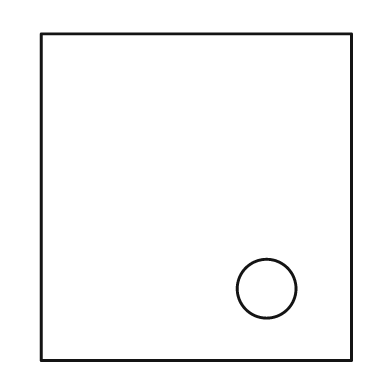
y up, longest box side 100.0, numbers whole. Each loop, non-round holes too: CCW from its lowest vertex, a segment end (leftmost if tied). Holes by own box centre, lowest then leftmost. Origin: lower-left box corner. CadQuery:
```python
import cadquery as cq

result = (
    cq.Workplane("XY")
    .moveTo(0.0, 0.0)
    .lineTo(95.0, 0.0)
    .lineTo(95.0, 100.0)
    .lineTo(0.0, 100.0)
    .close()
    .moveTo(69.0, 22.0)
    .circle(9.0)
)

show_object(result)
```